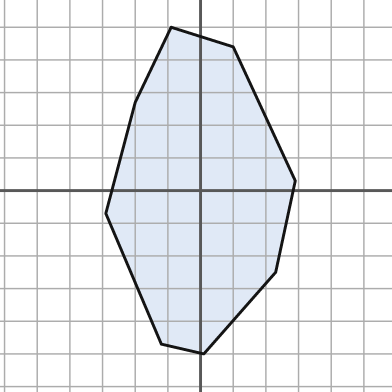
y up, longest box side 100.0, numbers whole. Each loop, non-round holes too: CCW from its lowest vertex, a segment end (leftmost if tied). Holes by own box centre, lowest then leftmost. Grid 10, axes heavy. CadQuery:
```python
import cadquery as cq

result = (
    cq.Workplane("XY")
    .moveTo(1.0, -50.0)
    .lineTo(23.0, -25.0)
    .lineTo(29.0, 3.0)
    .lineTo(10.0, 44.0)
    .lineTo(-9.0, 50.0)
    .lineTo(-20.0, 27.0)
    .lineTo(-29.0, -7.0)
    .lineTo(-12.0, -47.0)
    .close()
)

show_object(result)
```